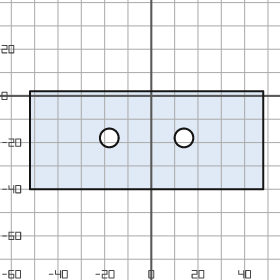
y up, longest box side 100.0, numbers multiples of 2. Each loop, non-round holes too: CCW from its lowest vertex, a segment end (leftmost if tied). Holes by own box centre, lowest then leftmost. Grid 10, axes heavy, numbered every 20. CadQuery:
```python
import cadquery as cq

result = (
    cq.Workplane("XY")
    .moveTo(-52.0, -40.0)
    .lineTo(48.0, -40.0)
    .lineTo(48.0, 2.0)
    .lineTo(-52.0, 2.0)
    .close()
    .moveTo(-18.0, -18.0)
    .circle(4.0)
    .moveTo(14.0, -18.0)
    .circle(4.0)
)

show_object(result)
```